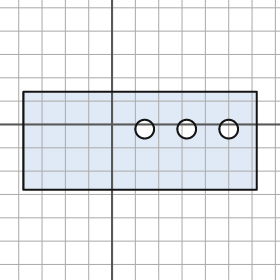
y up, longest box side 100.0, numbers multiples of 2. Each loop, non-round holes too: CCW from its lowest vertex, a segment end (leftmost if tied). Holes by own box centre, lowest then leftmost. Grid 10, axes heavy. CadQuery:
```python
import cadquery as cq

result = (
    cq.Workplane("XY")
    .moveTo(-38.0, -28.0)
    .lineTo(62.0, -28.0)
    .lineTo(62.0, 14.0)
    .lineTo(-38.0, 14.0)
    .close()
    .moveTo(14.0, -2.0)
    .circle(4.0)
    .moveTo(32.0, -2.0)
    .circle(4.0)
    .moveTo(50.0, -2.0)
    .circle(4.0)
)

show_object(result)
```